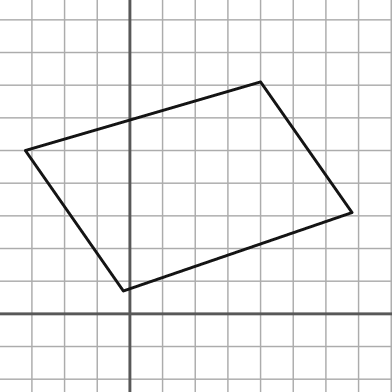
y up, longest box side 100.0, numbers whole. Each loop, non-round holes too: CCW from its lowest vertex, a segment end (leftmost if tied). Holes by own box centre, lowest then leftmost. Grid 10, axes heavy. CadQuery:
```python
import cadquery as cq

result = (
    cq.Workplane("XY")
    .moveTo(-2.0, 7.0)
    .lineTo(68.0, 31.0)
    .lineTo(40.0, 71.0)
    .lineTo(-32.0, 50.0)
    .close()
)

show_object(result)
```